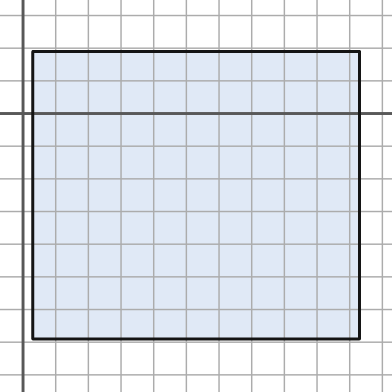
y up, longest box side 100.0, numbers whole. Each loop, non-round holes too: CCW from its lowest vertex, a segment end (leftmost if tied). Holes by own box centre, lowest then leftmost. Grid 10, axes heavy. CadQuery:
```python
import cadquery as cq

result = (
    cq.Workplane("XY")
    .moveTo(3.0, -69.0)
    .lineTo(103.0, -69.0)
    .lineTo(103.0, 19.0)
    .lineTo(3.0, 19.0)
    .close()
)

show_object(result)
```